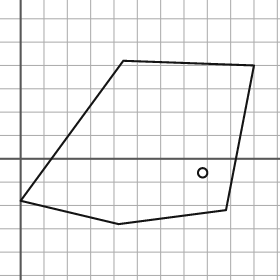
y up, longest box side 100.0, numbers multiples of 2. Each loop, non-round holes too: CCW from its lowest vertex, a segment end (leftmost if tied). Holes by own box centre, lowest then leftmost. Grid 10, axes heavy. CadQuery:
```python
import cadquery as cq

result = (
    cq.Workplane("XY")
    .moveTo(42.0, -28.0)
    .lineTo(88.0, -22.0)
    .lineTo(100.0, 40.0)
    .lineTo(44.0, 42.0)
    .lineTo(0.0, -18.0)
    .close()
    .moveTo(78.0, -6.0)
    .circle(2.0)
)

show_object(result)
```